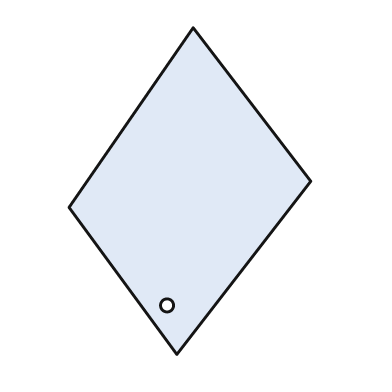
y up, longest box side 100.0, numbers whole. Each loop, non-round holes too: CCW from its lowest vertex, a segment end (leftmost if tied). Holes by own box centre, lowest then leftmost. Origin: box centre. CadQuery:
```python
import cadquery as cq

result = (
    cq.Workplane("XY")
    .moveTo(-4.0, -50.0)
    .lineTo(37.0, 3.0)
    .lineTo(1.0, 50.0)
    .lineTo(-37.0, -5.0)
    .close()
    .moveTo(-7.0, -35.0)
    .circle(2.0)
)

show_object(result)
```